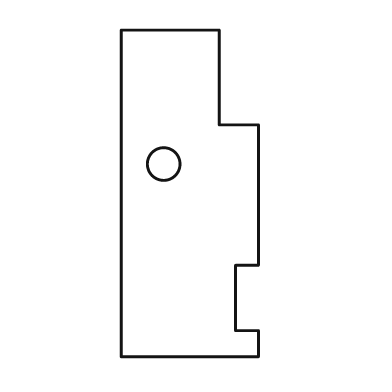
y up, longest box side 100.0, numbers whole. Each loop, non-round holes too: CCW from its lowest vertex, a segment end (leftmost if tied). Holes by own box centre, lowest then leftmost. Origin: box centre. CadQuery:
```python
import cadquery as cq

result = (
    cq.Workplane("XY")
    .moveTo(-21.0, -50.0)
    .lineTo(21.0, -50.0)
    .lineTo(21.0, -42.0)
    .lineTo(14.0, -42.0)
    .lineTo(14.0, -22.0)
    .lineTo(21.0, -22.0)
    .lineTo(21.0, 21.0)
    .lineTo(9.0, 21.0)
    .lineTo(9.0, 50.0)
    .lineTo(-21.0, 50.0)
    .close()
    .moveTo(-8.0, 9.0)
    .circle(5.0)
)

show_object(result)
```